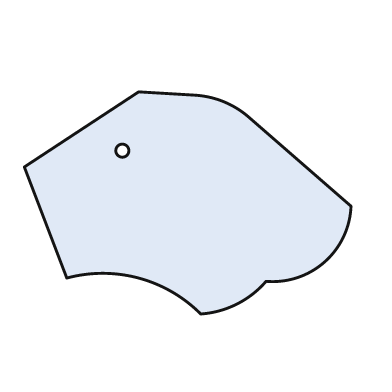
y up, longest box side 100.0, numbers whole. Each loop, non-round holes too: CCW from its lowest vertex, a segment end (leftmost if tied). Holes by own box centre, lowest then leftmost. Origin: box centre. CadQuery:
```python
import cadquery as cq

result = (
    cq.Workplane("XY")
    .moveTo(4.0, -34.0)
    .threePointArc((15.0, -31.0), (24.0, -24.0))
    .threePointArc((42.0, -18.0), (50.0, -1.0))
    .lineTo(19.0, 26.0)
    .threePointArc((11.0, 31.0), (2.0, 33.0))
    .lineTo(-15.0, 34.0)
    .lineTo(-50.0, 11.0)
    .lineTo(-37.0, -23.0)
    .threePointArc((-15.0, -23.0), (4.0, -34.0))
    .close()
    .moveTo(-20.0, 16.0)
    .circle(2.0)
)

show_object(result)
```